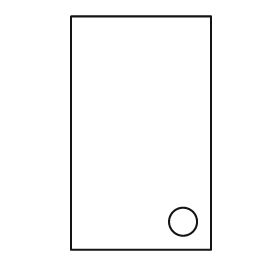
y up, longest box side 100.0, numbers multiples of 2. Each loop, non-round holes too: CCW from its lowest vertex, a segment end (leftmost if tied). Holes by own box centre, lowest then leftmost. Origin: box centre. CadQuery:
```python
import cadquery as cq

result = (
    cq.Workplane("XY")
    .moveTo(-30.0, -50.0)
    .lineTo(30.0, -50.0)
    .lineTo(30.0, 50.0)
    .lineTo(-30.0, 50.0)
    .close()
    .moveTo(18.0, -38.0)
    .circle(6.0)
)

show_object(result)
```